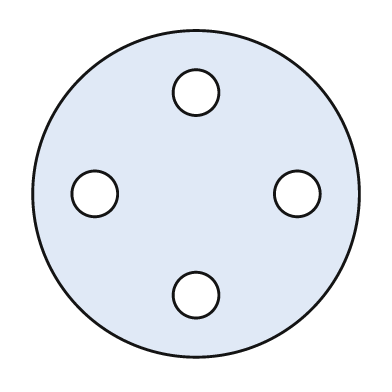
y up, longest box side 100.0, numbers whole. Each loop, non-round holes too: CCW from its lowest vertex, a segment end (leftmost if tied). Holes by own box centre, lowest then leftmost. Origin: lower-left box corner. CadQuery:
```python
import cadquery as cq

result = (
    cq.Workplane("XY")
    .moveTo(50.0, 50.0)
    .circle(50.0)
    .moveTo(50.0, 19.0)
    .circle(7.0)
    .moveTo(19.0, 50.0)
    .circle(7.0)
    .moveTo(81.0, 50.0)
    .circle(7.0)
    .moveTo(50.0, 81.0)
    .circle(7.0)
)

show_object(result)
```